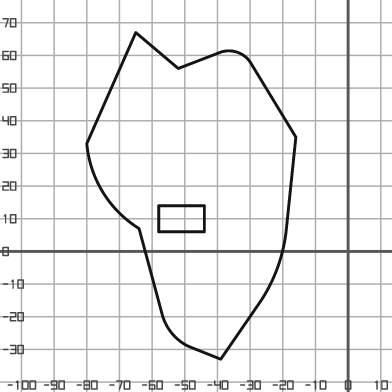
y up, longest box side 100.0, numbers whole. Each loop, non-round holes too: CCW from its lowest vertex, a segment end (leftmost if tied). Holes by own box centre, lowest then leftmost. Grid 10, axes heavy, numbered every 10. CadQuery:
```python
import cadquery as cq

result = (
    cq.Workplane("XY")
    .moveTo(-39.0, -33.0)
    .lineTo(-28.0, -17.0)
    .threePointArc((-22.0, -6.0), (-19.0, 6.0))
    .lineTo(-16.0, 35.0)
    .lineTo(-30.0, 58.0)
    .threePointArc((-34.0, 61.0), (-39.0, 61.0))
    .lineTo(-52.0, 56.0)
    .lineTo(-65.0, 67.0)
    .lineTo(-80.0, 33.0)
    .threePointArc((-75.0, 18.0), (-64.0, 7.0))
    .lineTo(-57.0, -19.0)
    .threePointArc((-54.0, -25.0), (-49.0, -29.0))
    .close()
    .moveTo(-58.0, 6.0)
    .lineTo(-44.0, 6.0)
    .lineTo(-44.0, 14.0)
    .lineTo(-58.0, 14.0)
    .close()
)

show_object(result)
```